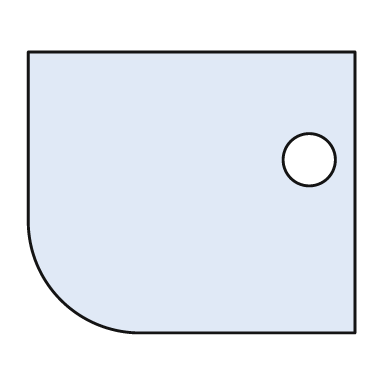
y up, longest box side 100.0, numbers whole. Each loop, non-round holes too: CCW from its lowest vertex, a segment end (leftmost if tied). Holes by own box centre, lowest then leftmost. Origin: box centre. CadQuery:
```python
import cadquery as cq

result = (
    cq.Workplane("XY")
    .moveTo(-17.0, -43.0)
    .lineTo(50.0, -43.0)
    .lineTo(50.0, 43.0)
    .lineTo(-50.0, 43.0)
    .lineTo(-50.0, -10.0)
    .threePointArc((-40.0, -33.0), (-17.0, -43.0))
    .close()
    .moveTo(36.0, 10.0)
    .circle(8.0)
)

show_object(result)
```